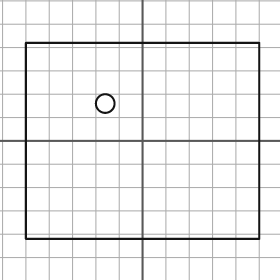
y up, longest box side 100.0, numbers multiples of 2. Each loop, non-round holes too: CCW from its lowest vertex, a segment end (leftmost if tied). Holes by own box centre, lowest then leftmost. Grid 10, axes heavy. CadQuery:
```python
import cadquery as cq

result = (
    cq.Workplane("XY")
    .moveTo(-50.0, -42.0)
    .lineTo(50.0, -42.0)
    .lineTo(50.0, 42.0)
    .lineTo(-50.0, 42.0)
    .close()
    .moveTo(-16.0, 16.0)
    .circle(4.0)
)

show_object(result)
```